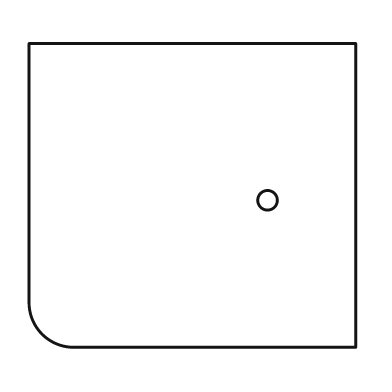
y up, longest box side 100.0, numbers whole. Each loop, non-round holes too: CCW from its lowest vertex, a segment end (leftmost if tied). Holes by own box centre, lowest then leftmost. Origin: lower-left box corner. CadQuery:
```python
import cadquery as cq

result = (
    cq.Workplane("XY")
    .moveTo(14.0, 0.0)
    .lineTo(100.0, 0.0)
    .lineTo(100.0, 93.0)
    .lineTo(0.0, 93.0)
    .lineTo(0.0, 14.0)
    .threePointArc((4.0, 4.0), (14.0, 0.0))
    .close()
    .moveTo(73.0, 45.0)
    .circle(3.0)
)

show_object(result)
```